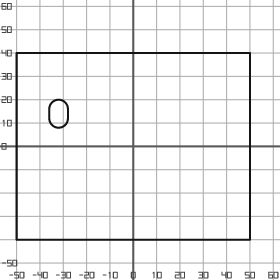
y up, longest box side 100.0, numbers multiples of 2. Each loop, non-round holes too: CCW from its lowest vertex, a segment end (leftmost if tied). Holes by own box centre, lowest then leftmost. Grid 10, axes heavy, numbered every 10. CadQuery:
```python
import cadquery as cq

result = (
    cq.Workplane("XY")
    .moveTo(-50.0, -40.0)
    .lineTo(50.0, -40.0)
    .lineTo(50.0, 40.0)
    .lineTo(-50.0, 40.0)
    .close()
    .moveTo(-36.0, 12.0)
    .threePointArc((-32.0, 8.0), (-28.0, 12.0))
    .lineTo(-28.0, 16.0)
    .threePointArc((-32.0, 20.0), (-36.0, 16.0))
    .close()
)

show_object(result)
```